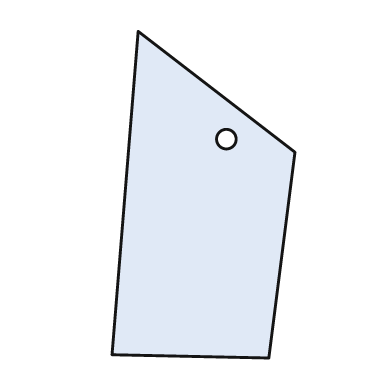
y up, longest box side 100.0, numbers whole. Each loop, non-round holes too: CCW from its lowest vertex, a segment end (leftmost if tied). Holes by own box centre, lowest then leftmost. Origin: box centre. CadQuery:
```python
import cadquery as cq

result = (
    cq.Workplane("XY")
    .moveTo(20.0, -50.0)
    .lineTo(28.0, 13.0)
    .lineTo(-20.0, 50.0)
    .lineTo(-28.0, -49.0)
    .close()
    .moveTo(7.0, 17.0)
    .circle(3.0)
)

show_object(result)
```